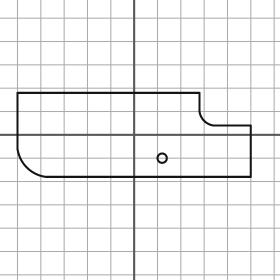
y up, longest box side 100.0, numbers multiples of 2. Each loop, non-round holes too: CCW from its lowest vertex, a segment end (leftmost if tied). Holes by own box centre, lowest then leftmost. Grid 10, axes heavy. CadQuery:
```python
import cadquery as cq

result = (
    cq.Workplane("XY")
    .moveTo(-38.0, -18.0)
    .lineTo(50.0, -18.0)
    .lineTo(50.0, 4.0)
    .lineTo(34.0, 4.0)
    .threePointArc((30.0, 6.0), (28.0, 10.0))
    .lineTo(28.0, 18.0)
    .lineTo(-50.0, 18.0)
    .lineTo(-50.0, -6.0)
    .threePointArc((-46.0, -14.0), (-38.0, -18.0))
    .close()
    .moveTo(12.0, -10.0)
    .circle(2.0)
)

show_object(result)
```